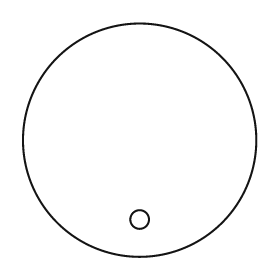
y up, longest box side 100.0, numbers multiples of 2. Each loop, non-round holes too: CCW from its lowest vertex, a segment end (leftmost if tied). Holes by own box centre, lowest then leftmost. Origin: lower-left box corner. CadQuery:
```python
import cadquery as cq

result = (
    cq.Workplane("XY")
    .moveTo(50.0, 50.0)
    .circle(50.0)
    .moveTo(50.0, 16.0)
    .circle(4.0)
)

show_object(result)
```